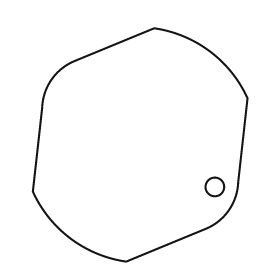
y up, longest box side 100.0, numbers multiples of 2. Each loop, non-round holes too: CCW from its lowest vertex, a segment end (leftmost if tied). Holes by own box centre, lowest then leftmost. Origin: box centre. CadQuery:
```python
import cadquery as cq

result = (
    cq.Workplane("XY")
    .moveTo(-6.0, -50.0)
    .lineTo(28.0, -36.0)
    .threePointArc((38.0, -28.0), (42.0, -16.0))
    .lineTo(46.0, 20.0)
    .threePointArc((30.0, 40.0), (6.0, 50.0))
    .lineTo(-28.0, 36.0)
    .threePointArc((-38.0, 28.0), (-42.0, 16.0))
    .lineTo(-46.0, -20.0)
    .threePointArc((-30.0, -40.0), (-6.0, -50.0))
    .close()
    .moveTo(32.0, -18.0)
    .circle(4.0)
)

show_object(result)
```